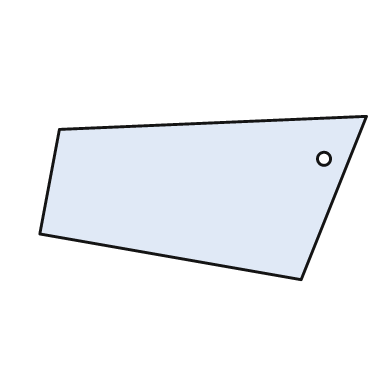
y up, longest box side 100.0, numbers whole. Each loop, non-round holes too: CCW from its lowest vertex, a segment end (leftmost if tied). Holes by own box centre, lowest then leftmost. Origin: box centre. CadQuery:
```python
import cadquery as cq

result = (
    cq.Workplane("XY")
    .moveTo(30.0, -25.0)
    .lineTo(50.0, 25.0)
    .lineTo(-44.0, 21.0)
    .lineTo(-50.0, -11.0)
    .close()
    .moveTo(37.0, 12.0)
    .circle(2.0)
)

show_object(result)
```